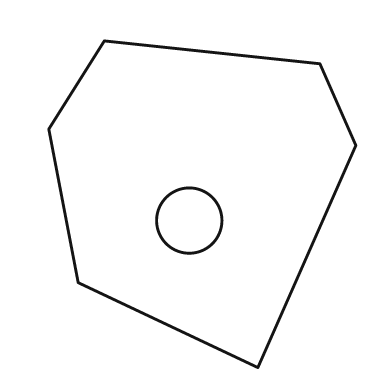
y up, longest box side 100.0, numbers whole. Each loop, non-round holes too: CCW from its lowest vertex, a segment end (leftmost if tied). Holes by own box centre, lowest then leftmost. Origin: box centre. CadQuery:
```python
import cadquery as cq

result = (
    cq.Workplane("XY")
    .moveTo(17.0, -50.0)
    .lineTo(47.0, 18.0)
    .lineTo(36.0, 43.0)
    .lineTo(-30.0, 50.0)
    .lineTo(-47.0, 23.0)
    .lineTo(-38.0, -24.0)
    .close()
    .moveTo(-4.0, -5.0)
    .circle(10.0)
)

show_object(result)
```